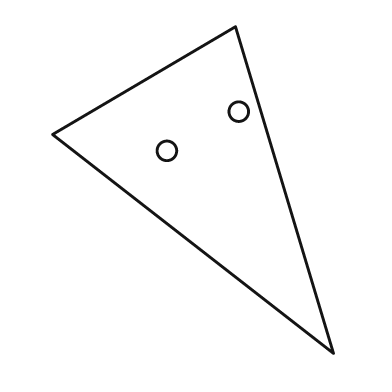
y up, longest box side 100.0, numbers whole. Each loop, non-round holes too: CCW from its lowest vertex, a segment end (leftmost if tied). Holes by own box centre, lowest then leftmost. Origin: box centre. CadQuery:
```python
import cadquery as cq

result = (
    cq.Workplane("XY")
    .moveTo(43.0, -50.0)
    .lineTo(13.0, 50.0)
    .lineTo(-43.0, 17.0)
    .close()
    .moveTo(-8.0, 12.0)
    .circle(3.0)
    .moveTo(14.0, 24.0)
    .circle(3.0)
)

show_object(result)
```